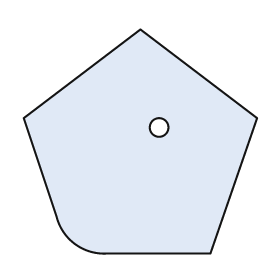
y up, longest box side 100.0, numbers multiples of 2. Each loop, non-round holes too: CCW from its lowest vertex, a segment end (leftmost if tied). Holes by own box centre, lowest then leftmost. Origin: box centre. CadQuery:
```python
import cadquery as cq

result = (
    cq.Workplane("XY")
    .moveTo(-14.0, -48.0)
    .lineTo(30.0, -48.0)
    .lineTo(50.0, 10.0)
    .lineTo(0.0, 48.0)
    .lineTo(-50.0, 10.0)
    .lineTo(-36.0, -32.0)
    .threePointArc((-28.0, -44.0), (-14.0, -48.0))
    .close()
    .moveTo(8.0, 6.0)
    .circle(4.0)
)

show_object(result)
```